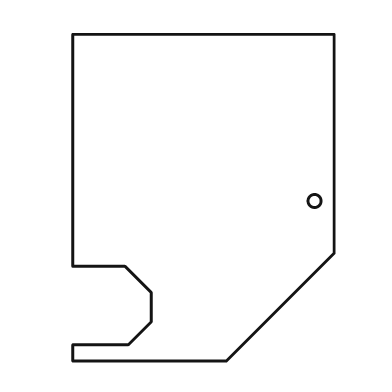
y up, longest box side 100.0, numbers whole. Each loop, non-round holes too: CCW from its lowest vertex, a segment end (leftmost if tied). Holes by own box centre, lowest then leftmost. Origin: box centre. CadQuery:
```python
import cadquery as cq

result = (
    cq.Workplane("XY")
    .moveTo(-40.0, -50.0)
    .lineTo(7.0, -50.0)
    .lineTo(40.0, -17.0)
    .lineTo(40.0, 50.0)
    .lineTo(-40.0, 50.0)
    .lineTo(-40.0, -21.0)
    .lineTo(-24.0, -21.0)
    .lineTo(-16.0, -29.0)
    .lineTo(-16.0, -38.0)
    .lineTo(-23.0, -45.0)
    .lineTo(-40.0, -45.0)
    .close()
    .moveTo(34.0, -1.0)
    .circle(2.0)
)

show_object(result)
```